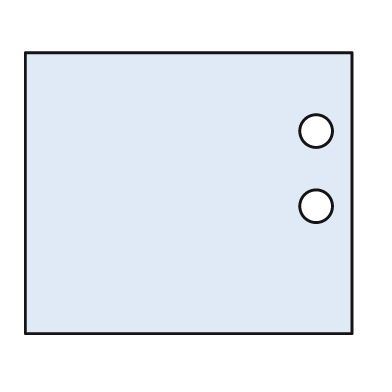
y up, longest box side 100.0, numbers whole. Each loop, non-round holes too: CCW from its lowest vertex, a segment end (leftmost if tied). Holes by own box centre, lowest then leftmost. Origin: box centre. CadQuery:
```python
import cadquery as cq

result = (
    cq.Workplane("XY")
    .moveTo(-50.0, -43.0)
    .lineTo(50.0, -43.0)
    .lineTo(50.0, 43.0)
    .lineTo(-50.0, 43.0)
    .close()
    .moveTo(39.0, -4.0)
    .circle(5.0)
    .moveTo(39.0, 19.0)
    .circle(5.0)
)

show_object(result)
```